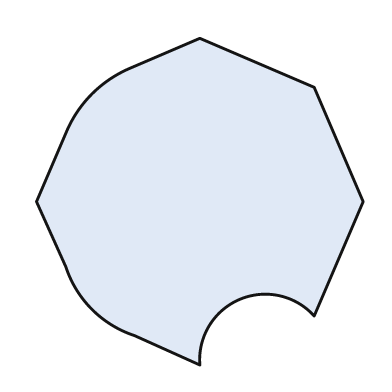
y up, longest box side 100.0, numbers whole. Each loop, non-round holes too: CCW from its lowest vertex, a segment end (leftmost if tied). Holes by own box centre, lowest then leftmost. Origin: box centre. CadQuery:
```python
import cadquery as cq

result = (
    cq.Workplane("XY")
    .moveTo(0.0, -50.0)
    .threePointArc((12.0, -30.0), (35.0, -35.0))
    .lineTo(50.0, 0.0)
    .lineTo(35.0, 35.0)
    .lineTo(0.0, 50.0)
    .lineTo(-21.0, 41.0)
    .threePointArc((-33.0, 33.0), (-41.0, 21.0))
    .lineTo(-50.0, 0.0)
    .lineTo(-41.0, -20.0)
    .threePointArc((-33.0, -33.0), (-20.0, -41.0))
    .close()
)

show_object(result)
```